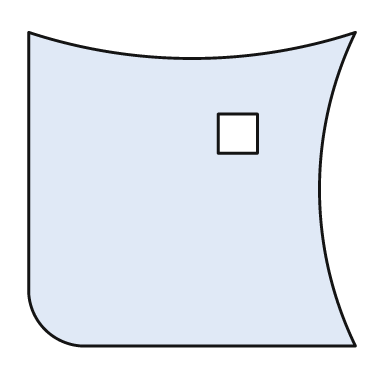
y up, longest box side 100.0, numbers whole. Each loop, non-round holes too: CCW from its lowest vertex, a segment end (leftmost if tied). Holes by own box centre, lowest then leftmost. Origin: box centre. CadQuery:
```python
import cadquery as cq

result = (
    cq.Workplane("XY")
    .moveTo(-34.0, -48.0)
    .lineTo(50.0, -48.0)
    .threePointArc((39.0, 0.0), (50.0, 48.0))
    .threePointArc((0.0, 40.0), (-50.0, 48.0))
    .lineTo(-50.0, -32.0)
    .threePointArc((-45.0, -43.0), (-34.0, -48.0))
    .close()
    .moveTo(8.0, 11.0)
    .lineTo(20.0, 11.0)
    .lineTo(20.0, 23.0)
    .lineTo(8.0, 23.0)
    .close()
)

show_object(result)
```